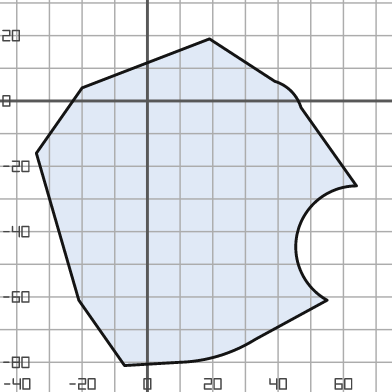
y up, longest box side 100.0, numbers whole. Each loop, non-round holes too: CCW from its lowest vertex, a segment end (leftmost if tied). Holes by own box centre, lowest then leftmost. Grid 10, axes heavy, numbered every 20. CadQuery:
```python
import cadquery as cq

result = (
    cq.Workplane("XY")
    .moveTo(-7.0, -81.0)
    .lineTo(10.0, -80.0)
    .threePointArc((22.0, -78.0), (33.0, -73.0))
    .lineTo(55.0, -61.0)
    .threePointArc((46.0, -40.0), (64.0, -26.0))
    .lineTo(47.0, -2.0)
    .threePointArc((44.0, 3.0), (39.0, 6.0))
    .lineTo(19.0, 19.0)
    .lineTo(-20.0, 4.0)
    .lineTo(-34.0, -16.0)
    .lineTo(-21.0, -61.0)
    .close()
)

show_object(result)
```